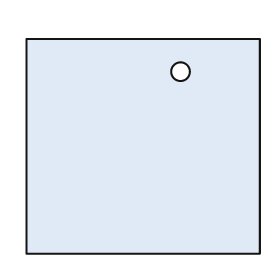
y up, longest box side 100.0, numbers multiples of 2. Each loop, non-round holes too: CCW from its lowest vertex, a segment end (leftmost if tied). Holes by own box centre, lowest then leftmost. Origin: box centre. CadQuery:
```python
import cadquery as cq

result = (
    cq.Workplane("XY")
    .moveTo(-50.0, -46.0)
    .lineTo(50.0, -46.0)
    .lineTo(50.0, 46.0)
    .lineTo(-50.0, 46.0)
    .close()
    .moveTo(16.0, 32.0)
    .circle(4.0)
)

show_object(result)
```